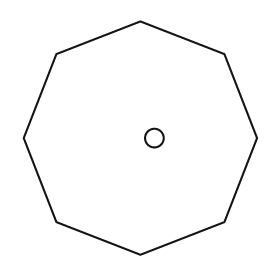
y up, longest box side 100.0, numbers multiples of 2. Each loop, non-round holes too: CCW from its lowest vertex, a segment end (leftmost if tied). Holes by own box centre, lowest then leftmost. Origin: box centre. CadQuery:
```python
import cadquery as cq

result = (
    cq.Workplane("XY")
    .moveTo(0.0, -50.0)
    .lineTo(36.0, -36.0)
    .lineTo(50.0, 0.0)
    .lineTo(36.0, 36.0)
    .lineTo(0.0, 50.0)
    .lineTo(-36.0, 36.0)
    .lineTo(-50.0, 0.0)
    .lineTo(-36.0, -36.0)
    .close()
    .moveTo(6.0, 0.0)
    .circle(4.0)
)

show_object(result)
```